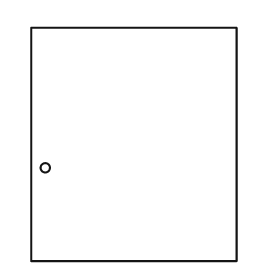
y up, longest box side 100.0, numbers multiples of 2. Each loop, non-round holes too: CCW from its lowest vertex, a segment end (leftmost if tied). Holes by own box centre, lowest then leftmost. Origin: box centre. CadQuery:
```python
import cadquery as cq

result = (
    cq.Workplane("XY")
    .moveTo(-44.0, -50.0)
    .lineTo(44.0, -50.0)
    .lineTo(44.0, 50.0)
    .lineTo(-44.0, 50.0)
    .close()
    .moveTo(-38.0, -10.0)
    .circle(2.0)
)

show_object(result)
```